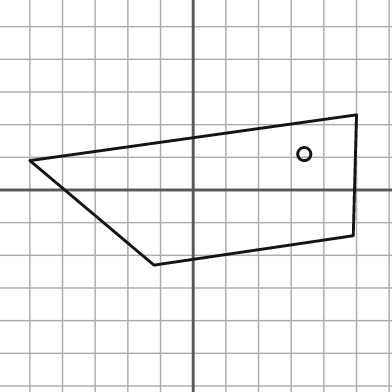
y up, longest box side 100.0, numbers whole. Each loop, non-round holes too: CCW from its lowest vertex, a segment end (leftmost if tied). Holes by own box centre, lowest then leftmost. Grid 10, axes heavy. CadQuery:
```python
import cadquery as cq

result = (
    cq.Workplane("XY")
    .moveTo(-12.0, -23.0)
    .lineTo(49.0, -14.0)
    .lineTo(50.0, 23.0)
    .lineTo(-50.0, 9.0)
    .close()
    .moveTo(34.0, 11.0)
    .circle(2.0)
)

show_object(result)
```